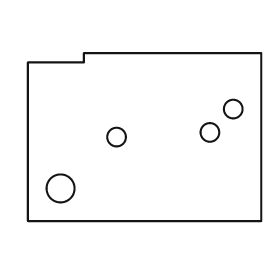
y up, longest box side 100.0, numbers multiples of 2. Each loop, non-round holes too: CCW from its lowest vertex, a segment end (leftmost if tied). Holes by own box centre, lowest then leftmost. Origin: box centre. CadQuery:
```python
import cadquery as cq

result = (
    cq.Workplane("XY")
    .moveTo(-50.0, -36.0)
    .lineTo(50.0, -36.0)
    .lineTo(50.0, 36.0)
    .lineTo(-26.0, 36.0)
    .lineTo(-26.0, 32.0)
    .lineTo(-50.0, 32.0)
    .close()
    .moveTo(-36.0, -22.0)
    .circle(6.0)
    .moveTo(-12.0, 0.0)
    .circle(4.0)
    .moveTo(28.0, 2.0)
    .circle(4.0)
    .moveTo(38.0, 12.0)
    .circle(4.0)
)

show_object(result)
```